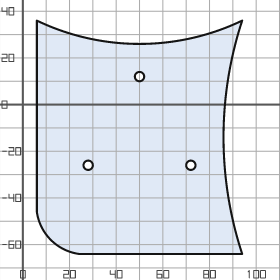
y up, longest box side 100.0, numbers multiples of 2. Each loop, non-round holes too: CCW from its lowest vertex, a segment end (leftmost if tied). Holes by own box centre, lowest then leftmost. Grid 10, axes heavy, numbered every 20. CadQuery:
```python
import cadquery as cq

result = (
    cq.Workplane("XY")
    .moveTo(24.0, -64.0)
    .lineTo(94.0, -64.0)
    .threePointArc((86.0, -14.0), (94.0, 36.0))
    .threePointArc((50.0, 26.0), (6.0, 36.0))
    .lineTo(6.0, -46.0)
    .threePointArc((12.0, -58.0), (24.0, -64.0))
    .close()
    .moveTo(28.0, -26.0)
    .circle(2.0)
    .moveTo(72.0, -26.0)
    .circle(2.0)
    .moveTo(50.0, 12.0)
    .circle(2.0)
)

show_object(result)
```